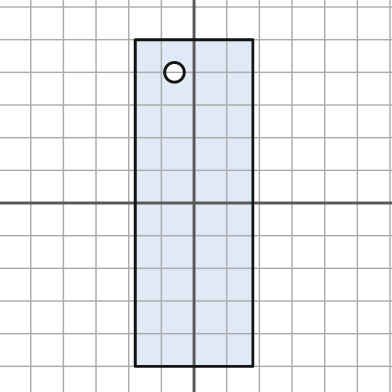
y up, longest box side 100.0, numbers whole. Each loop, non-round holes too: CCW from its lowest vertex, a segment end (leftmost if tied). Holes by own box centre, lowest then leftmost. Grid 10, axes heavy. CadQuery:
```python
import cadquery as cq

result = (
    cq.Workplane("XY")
    .moveTo(-18.0, -50.0)
    .lineTo(18.0, -50.0)
    .lineTo(18.0, 50.0)
    .lineTo(-18.0, 50.0)
    .close()
    .moveTo(-6.0, 40.0)
    .circle(3.0)
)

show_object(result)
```